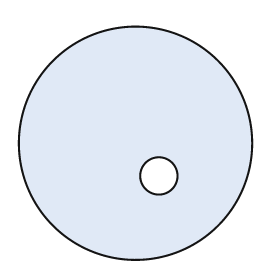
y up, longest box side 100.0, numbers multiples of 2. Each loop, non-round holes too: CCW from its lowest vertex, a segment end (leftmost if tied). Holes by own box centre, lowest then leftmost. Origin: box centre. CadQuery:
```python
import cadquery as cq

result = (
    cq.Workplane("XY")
    .moveTo(0.0, 0.0)
    .circle(50.0)
    .moveTo(10.0, -14.0)
    .circle(8.0)
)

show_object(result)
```